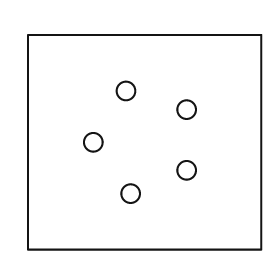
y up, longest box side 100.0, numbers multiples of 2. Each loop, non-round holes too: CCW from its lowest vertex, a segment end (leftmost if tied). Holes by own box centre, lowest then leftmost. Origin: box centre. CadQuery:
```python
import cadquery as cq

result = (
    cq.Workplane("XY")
    .moveTo(-50.0, -46.0)
    .lineTo(50.0, -46.0)
    .lineTo(50.0, 46.0)
    .lineTo(-50.0, 46.0)
    .close()
    .moveTo(-6.0, -22.0)
    .circle(4.0)
    .moveTo(18.0, -12.0)
    .circle(4.0)
    .moveTo(-22.0, 0.0)
    .circle(4.0)
    .moveTo(18.0, 14.0)
    .circle(4.0)
    .moveTo(-8.0, 22.0)
    .circle(4.0)
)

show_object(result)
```